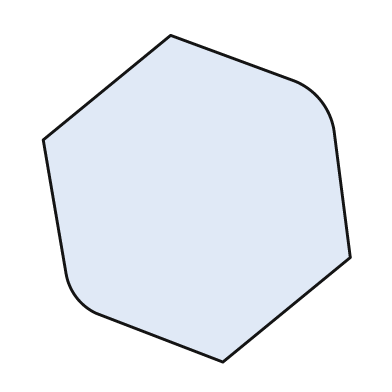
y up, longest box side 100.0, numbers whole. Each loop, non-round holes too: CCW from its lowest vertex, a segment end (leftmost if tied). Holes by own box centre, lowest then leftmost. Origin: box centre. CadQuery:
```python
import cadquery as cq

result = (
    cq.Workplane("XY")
    .moveTo(8.0, -50.0)
    .lineTo(47.0, -18.0)
    .lineTo(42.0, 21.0)
    .threePointArc((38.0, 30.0), (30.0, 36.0))
    .lineTo(-8.0, 50.0)
    .lineTo(-47.0, 18.0)
    .lineTo(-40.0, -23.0)
    .threePointArc((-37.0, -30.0), (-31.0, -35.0))
    .close()
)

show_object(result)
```